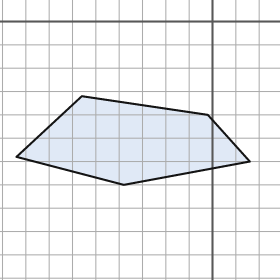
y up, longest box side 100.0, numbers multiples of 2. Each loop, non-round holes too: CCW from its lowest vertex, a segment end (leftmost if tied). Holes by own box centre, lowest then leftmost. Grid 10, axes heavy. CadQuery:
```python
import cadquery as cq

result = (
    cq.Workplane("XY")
    .moveTo(-38.0, -70.0)
    .lineTo(16.0, -60.0)
    .lineTo(-2.0, -40.0)
    .lineTo(-56.0, -32.0)
    .lineTo(-84.0, -58.0)
    .close()
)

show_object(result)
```